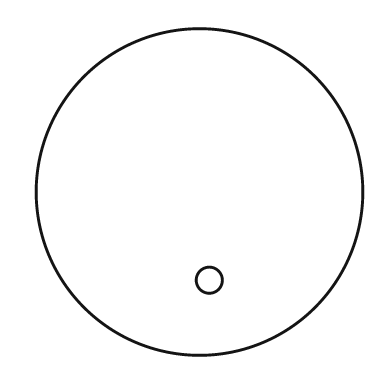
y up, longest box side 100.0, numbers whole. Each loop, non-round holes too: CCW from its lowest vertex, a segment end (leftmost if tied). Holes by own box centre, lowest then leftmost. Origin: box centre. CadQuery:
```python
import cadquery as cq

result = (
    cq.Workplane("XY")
    .moveTo(0.0, 0.0)
    .circle(50.0)
    .moveTo(3.0, -27.0)
    .circle(4.0)
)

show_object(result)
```